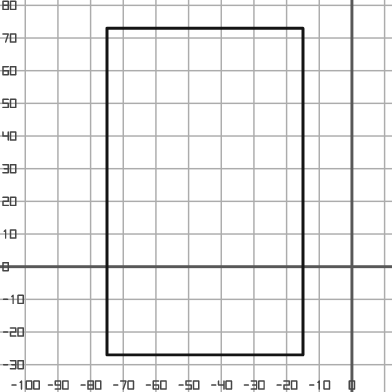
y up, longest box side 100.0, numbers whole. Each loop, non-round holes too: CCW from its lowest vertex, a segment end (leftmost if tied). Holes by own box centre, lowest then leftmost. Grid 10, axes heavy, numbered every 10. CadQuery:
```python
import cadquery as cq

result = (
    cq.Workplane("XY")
    .moveTo(-75.0, -27.0)
    .lineTo(-15.0, -27.0)
    .lineTo(-15.0, 73.0)
    .lineTo(-75.0, 73.0)
    .close()
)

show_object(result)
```